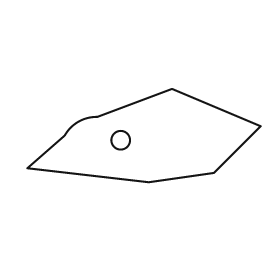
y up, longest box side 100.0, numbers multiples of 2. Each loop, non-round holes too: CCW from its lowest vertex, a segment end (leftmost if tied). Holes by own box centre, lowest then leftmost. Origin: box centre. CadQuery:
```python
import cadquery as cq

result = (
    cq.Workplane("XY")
    .moveTo(2.0, -20.0)
    .lineTo(30.0, -16.0)
    .lineTo(50.0, 4.0)
    .lineTo(12.0, 20.0)
    .lineTo(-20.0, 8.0)
    .threePointArc((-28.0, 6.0), (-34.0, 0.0))
    .lineTo(-50.0, -14.0)
    .close()
    .moveTo(-10.0, -2.0)
    .circle(4.0)
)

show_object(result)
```